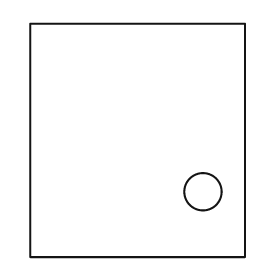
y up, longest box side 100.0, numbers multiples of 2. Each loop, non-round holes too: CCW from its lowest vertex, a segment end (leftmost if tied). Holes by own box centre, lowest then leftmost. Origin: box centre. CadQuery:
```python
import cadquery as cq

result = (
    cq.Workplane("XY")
    .moveTo(-46.0, -50.0)
    .lineTo(46.0, -50.0)
    .lineTo(46.0, 50.0)
    .lineTo(-46.0, 50.0)
    .close()
    .moveTo(28.0, -22.0)
    .circle(8.0)
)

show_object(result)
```